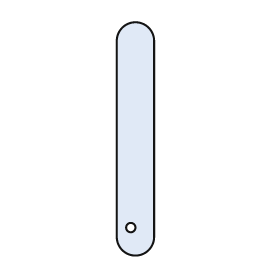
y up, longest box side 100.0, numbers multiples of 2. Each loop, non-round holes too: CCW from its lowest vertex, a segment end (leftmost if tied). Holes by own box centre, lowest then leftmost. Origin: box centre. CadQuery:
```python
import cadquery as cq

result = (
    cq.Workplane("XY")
    .moveTo(-8.0, -42.0)
    .threePointArc((0.0, -50.0), (8.0, -42.0))
    .lineTo(8.0, 42.0)
    .threePointArc((0.0, 50.0), (-8.0, 42.0))
    .close()
    .moveTo(-2.0, -38.0)
    .circle(2.0)
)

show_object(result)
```